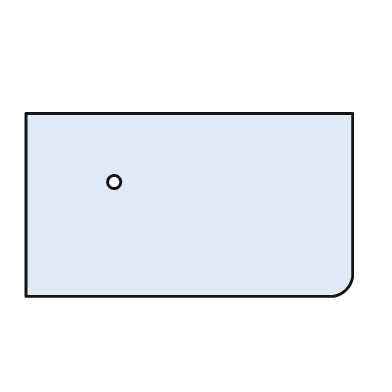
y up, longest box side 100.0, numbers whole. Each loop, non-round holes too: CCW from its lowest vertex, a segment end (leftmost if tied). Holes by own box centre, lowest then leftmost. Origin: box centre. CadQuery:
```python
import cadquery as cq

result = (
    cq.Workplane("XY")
    .moveTo(-50.0, -28.0)
    .lineTo(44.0, -28.0)
    .threePointArc((48.0, -26.0), (50.0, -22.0))
    .lineTo(50.0, 28.0)
    .lineTo(-50.0, 28.0)
    .close()
    .moveTo(-23.0, 7.0)
    .circle(2.0)
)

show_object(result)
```